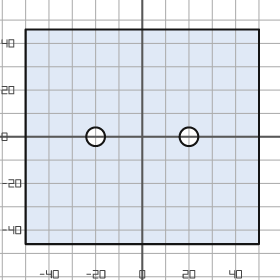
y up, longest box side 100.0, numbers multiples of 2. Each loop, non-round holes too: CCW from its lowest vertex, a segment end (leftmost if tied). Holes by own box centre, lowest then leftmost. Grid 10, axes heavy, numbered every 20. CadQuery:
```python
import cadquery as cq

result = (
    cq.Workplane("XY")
    .moveTo(-50.0, -46.0)
    .lineTo(50.0, -46.0)
    .lineTo(50.0, 46.0)
    .lineTo(-50.0, 46.0)
    .close()
    .moveTo(-20.0, 0.0)
    .circle(4.0)
    .moveTo(20.0, 0.0)
    .circle(4.0)
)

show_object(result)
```